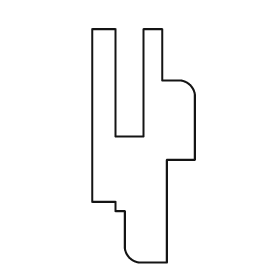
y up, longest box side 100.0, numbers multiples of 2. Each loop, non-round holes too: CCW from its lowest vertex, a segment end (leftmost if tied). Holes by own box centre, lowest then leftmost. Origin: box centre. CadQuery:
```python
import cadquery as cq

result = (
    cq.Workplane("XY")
    .moveTo(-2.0, -50.0)
    .lineTo(10.0, -50.0)
    .lineTo(10.0, -6.0)
    .lineTo(22.0, -6.0)
    .lineTo(22.0, 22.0)
    .threePointArc((20.0, 26.0), (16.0, 28.0))
    .lineTo(8.0, 28.0)
    .lineTo(8.0, 50.0)
    .lineTo(0.0, 50.0)
    .lineTo(0.0, 4.0)
    .lineTo(-12.0, 4.0)
    .lineTo(-12.0, 50.0)
    .lineTo(-22.0, 50.0)
    .lineTo(-22.0, -24.0)
    .lineTo(-12.0, -24.0)
    .lineTo(-12.0, -28.0)
    .lineTo(-8.0, -28.0)
    .lineTo(-8.0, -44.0)
    .threePointArc((-6.0, -48.0), (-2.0, -50.0))
    .close()
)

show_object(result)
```